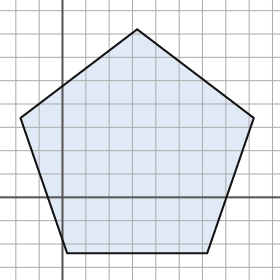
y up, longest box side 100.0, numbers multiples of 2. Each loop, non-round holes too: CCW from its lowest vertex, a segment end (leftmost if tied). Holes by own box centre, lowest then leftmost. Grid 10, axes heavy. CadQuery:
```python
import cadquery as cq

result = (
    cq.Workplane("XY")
    .moveTo(2.0, -24.0)
    .lineTo(62.0, -24.0)
    .lineTo(82.0, 34.0)
    .lineTo(32.0, 72.0)
    .lineTo(-18.0, 34.0)
    .close()
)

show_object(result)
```